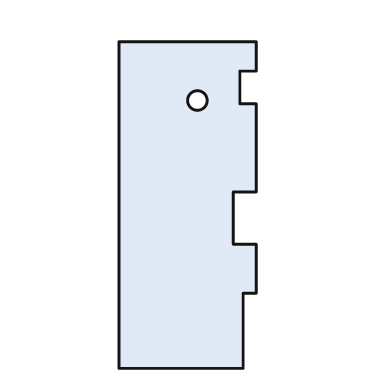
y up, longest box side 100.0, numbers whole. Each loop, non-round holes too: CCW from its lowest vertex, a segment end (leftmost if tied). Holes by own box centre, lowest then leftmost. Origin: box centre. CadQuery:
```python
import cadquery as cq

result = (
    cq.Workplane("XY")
    .moveTo(-21.0, -50.0)
    .lineTo(17.0, -50.0)
    .lineTo(17.0, -27.0)
    .lineTo(21.0, -27.0)
    .lineTo(21.0, -12.0)
    .lineTo(14.0, -12.0)
    .lineTo(14.0, 4.0)
    .lineTo(21.0, 4.0)
    .lineTo(21.0, 31.0)
    .lineTo(16.0, 31.0)
    .lineTo(16.0, 41.0)
    .lineTo(21.0, 41.0)
    .lineTo(21.0, 50.0)
    .lineTo(-21.0, 50.0)
    .close()
    .moveTo(3.0, 32.0)
    .circle(3.0)
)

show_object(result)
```